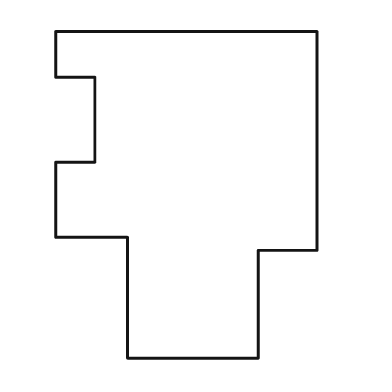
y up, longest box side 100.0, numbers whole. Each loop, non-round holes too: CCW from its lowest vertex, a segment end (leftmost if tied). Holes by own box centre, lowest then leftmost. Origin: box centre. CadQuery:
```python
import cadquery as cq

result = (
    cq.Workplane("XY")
    .moveTo(-18.0, -50.0)
    .lineTo(22.0, -50.0)
    .lineTo(22.0, -17.0)
    .lineTo(40.0, -17.0)
    .lineTo(40.0, 50.0)
    .lineTo(-40.0, 50.0)
    .lineTo(-40.0, 36.0)
    .lineTo(-28.0, 36.0)
    .lineTo(-28.0, 10.0)
    .lineTo(-40.0, 10.0)
    .lineTo(-40.0, -13.0)
    .lineTo(-18.0, -13.0)
    .close()
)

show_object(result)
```